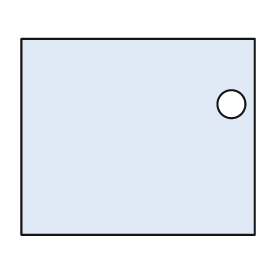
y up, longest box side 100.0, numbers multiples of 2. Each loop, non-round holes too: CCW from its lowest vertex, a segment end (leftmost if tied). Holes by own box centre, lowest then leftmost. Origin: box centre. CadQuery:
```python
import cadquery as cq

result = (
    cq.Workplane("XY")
    .moveTo(-50.0, -42.0)
    .lineTo(50.0, -42.0)
    .lineTo(50.0, 42.0)
    .lineTo(-50.0, 42.0)
    .close()
    .moveTo(40.0, 14.0)
    .circle(6.0)
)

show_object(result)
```